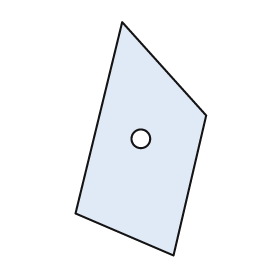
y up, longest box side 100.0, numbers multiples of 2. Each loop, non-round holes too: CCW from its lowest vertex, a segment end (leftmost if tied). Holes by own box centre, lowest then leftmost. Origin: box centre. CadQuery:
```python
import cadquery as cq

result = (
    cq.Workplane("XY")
    .moveTo(14.0, -50.0)
    .lineTo(28.0, 10.0)
    .lineTo(-8.0, 50.0)
    .lineTo(-28.0, -32.0)
    .close()
    .moveTo(0.0, 0.0)
    .circle(4.0)
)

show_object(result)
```